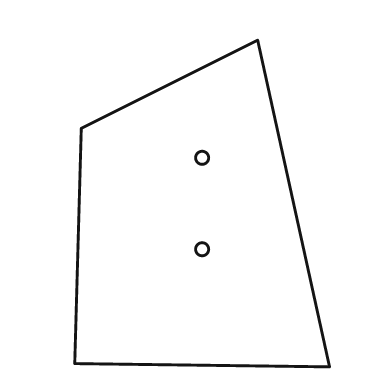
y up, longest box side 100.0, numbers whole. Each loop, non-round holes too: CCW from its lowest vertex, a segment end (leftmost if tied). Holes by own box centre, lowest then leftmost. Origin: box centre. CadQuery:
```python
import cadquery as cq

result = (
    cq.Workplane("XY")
    .moveTo(39.0, -50.0)
    .lineTo(17.0, 50.0)
    .lineTo(-37.0, 23.0)
    .lineTo(-39.0, -49.0)
    .close()
    .moveTo(0.0, -14.0)
    .circle(2.0)
    .moveTo(0.0, 14.0)
    .circle(2.0)
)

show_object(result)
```